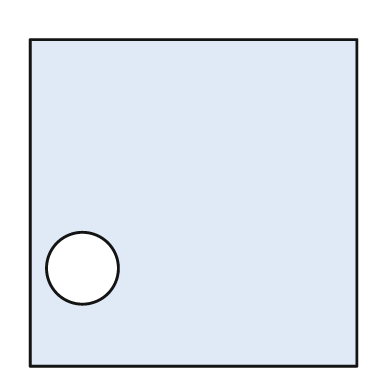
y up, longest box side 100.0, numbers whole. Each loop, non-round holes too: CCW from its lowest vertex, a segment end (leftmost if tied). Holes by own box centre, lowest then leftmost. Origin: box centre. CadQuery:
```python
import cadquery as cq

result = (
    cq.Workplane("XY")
    .moveTo(-50.0, -50.0)
    .lineTo(50.0, -50.0)
    .lineTo(50.0, 50.0)
    .lineTo(-50.0, 50.0)
    .close()
    .moveTo(-34.0, -20.0)
    .circle(11.0)
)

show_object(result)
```